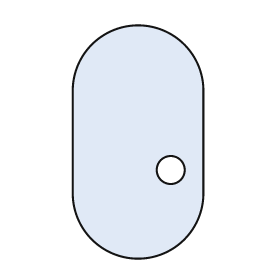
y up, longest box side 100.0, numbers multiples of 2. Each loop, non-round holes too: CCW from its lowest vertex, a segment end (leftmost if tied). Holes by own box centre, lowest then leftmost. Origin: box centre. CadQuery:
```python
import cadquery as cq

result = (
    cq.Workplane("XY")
    .moveTo(-28.0, -22.0)
    .threePointArc((0.0, -50.0), (28.0, -22.0))
    .lineTo(28.0, 22.0)
    .threePointArc((0.0, 50.0), (-28.0, 22.0))
    .close()
    .moveTo(14.0, -12.0)
    .circle(6.0)
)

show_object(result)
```